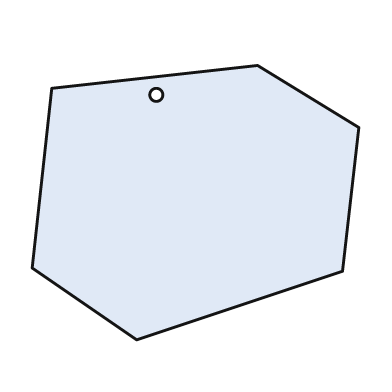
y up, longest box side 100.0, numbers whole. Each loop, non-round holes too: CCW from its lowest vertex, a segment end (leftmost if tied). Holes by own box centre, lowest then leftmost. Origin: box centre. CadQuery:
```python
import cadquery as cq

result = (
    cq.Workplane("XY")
    .moveTo(-18.0, -42.0)
    .lineTo(45.0, -21.0)
    .lineTo(50.0, 23.0)
    .lineTo(19.0, 42.0)
    .lineTo(-44.0, 35.0)
    .lineTo(-50.0, -20.0)
    .close()
    .moveTo(-12.0, 33.0)
    .circle(2.0)
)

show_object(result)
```